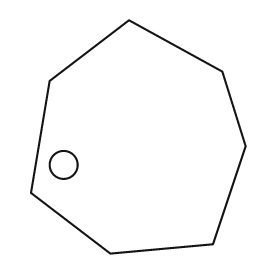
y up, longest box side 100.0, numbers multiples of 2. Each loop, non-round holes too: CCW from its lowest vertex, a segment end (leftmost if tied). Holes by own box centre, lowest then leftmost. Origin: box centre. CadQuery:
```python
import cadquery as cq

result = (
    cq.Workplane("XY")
    .moveTo(-12.0, -50.0)
    .lineTo(32.0, -46.0)
    .lineTo(46.0, -4.0)
    .lineTo(36.0, 28.0)
    .lineTo(-4.0, 50.0)
    .lineTo(-38.0, 24.0)
    .lineTo(-46.0, -24.0)
    .close()
    .moveTo(-32.0, -12.0)
    .circle(6.0)
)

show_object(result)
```